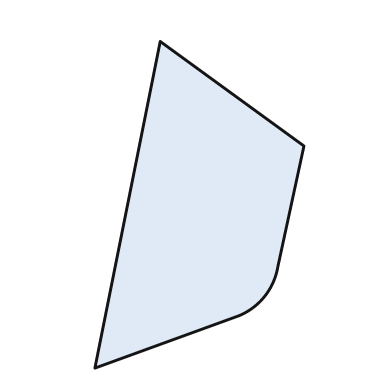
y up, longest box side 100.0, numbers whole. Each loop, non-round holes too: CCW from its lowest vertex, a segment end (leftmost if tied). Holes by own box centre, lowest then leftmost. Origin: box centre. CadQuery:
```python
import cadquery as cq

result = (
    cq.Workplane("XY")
    .moveTo(-32.0, -50.0)
    .lineTo(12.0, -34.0)
    .threePointArc((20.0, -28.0), (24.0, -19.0))
    .lineTo(32.0, 18.0)
    .lineTo(-12.0, 50.0)
    .close()
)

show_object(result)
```